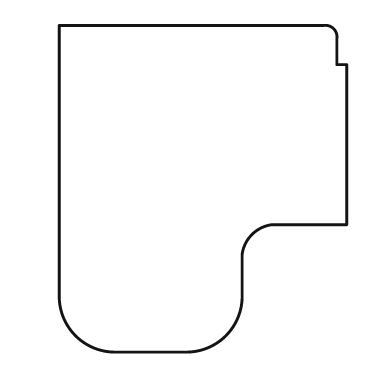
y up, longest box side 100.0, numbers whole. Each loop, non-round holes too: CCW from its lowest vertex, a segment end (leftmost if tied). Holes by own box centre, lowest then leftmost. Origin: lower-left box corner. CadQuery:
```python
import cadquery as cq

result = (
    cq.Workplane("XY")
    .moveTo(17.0, 0.0)
    .lineTo(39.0, 0.0)
    .threePointArc((51.0, 5.0), (56.0, 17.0))
    .lineTo(56.0, 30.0)
    .threePointArc((59.0, 36.0), (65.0, 39.0))
    .lineTo(88.0, 39.0)
    .lineTo(88.0, 88.0)
    .lineTo(85.0, 88.0)
    .lineTo(85.0, 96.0)
    .threePointArc((84.0, 99.0), (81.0, 100.0))
    .lineTo(0.0, 100.0)
    .lineTo(0.0, 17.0)
    .threePointArc((5.0, 5.0), (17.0, 0.0))
    .close()
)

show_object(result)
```